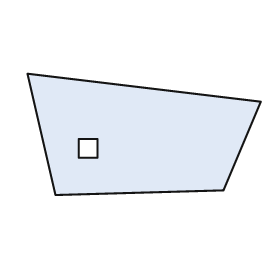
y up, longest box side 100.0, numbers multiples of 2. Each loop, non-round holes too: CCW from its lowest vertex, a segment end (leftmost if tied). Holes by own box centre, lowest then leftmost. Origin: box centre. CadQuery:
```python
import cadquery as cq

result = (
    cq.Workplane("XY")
    .moveTo(-38.0, -26.0)
    .lineTo(34.0, -24.0)
    .lineTo(50.0, 14.0)
    .lineTo(-50.0, 26.0)
    .close()
    .moveTo(-28.0, -10.0)
    .lineTo(-20.0, -10.0)
    .lineTo(-20.0, -2.0)
    .lineTo(-28.0, -2.0)
    .close()
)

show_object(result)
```